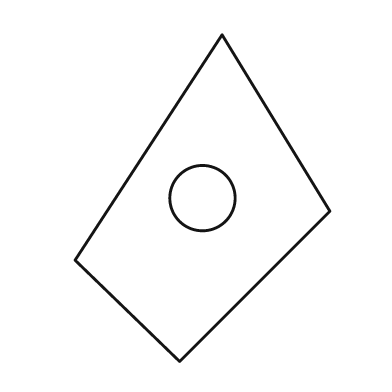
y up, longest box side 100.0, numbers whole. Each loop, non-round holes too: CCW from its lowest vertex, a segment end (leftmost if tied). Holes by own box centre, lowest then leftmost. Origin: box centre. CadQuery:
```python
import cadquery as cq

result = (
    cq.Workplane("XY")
    .moveTo(-7.0, -50.0)
    .lineTo(39.0, -4.0)
    .lineTo(6.0, 50.0)
    .lineTo(-39.0, -19.0)
    .close()
    .moveTo(0.0, 0.0)
    .circle(10.0)
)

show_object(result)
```